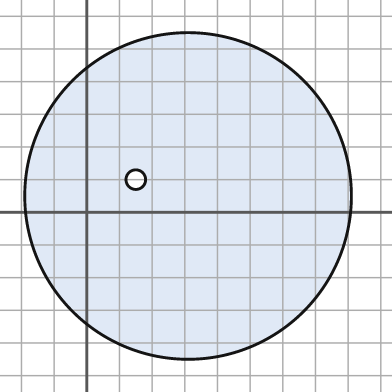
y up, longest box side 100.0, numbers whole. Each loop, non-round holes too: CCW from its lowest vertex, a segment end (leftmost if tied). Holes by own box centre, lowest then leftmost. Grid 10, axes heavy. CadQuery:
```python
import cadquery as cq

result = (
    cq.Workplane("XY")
    .moveTo(31.0, 5.0)
    .circle(50.0)
    .moveTo(15.0, 10.0)
    .circle(3.0)
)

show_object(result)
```